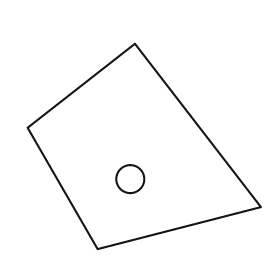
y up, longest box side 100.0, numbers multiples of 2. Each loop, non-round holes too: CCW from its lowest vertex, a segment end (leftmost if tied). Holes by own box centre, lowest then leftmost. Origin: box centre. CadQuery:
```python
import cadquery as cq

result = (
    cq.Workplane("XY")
    .moveTo(-20.0, -44.0)
    .lineTo(50.0, -26.0)
    .lineTo(-4.0, 44.0)
    .lineTo(-50.0, 8.0)
    .close()
    .moveTo(-6.0, -14.0)
    .circle(6.0)
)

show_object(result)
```